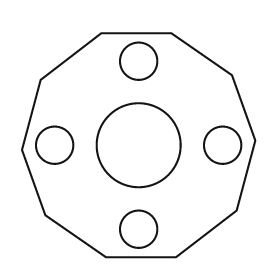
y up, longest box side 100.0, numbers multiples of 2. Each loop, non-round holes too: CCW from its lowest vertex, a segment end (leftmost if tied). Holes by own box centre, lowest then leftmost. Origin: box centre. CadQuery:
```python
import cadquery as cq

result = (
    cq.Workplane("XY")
    .moveTo(-14.0, -48.0)
    .lineTo(16.0, -48.0)
    .lineTo(42.0, -28.0)
    .lineTo(50.0, 2.0)
    .lineTo(40.0, 30.0)
    .lineTo(14.0, 48.0)
    .lineTo(-16.0, 48.0)
    .lineTo(-42.0, 28.0)
    .lineTo(-50.0, -2.0)
    .lineTo(-40.0, -30.0)
    .close()
    .moveTo(0.0, -36.0)
    .circle(8.0)
    .moveTo(-36.0, 0.0)
    .circle(8.0)
    .moveTo(0.0, 0.0)
    .circle(18.0)
    .moveTo(36.0, 0.0)
    .circle(8.0)
    .moveTo(0.0, 36.0)
    .circle(8.0)
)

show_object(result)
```